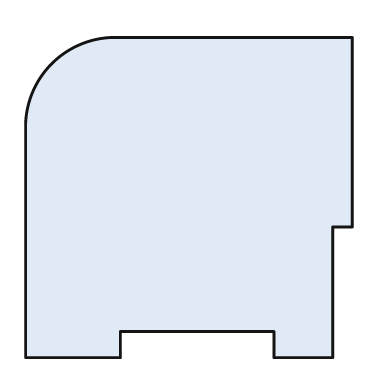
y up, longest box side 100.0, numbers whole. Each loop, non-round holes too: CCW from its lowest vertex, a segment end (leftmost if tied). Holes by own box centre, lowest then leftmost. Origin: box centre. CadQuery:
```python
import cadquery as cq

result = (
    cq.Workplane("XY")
    .moveTo(-50.0, -49.0)
    .lineTo(-21.0, -49.0)
    .lineTo(-21.0, -41.0)
    .lineTo(26.0, -41.0)
    .lineTo(26.0, -49.0)
    .lineTo(44.0, -49.0)
    .lineTo(44.0, -9.0)
    .lineTo(50.0, -9.0)
    .lineTo(50.0, 49.0)
    .lineTo(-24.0, 49.0)
    .threePointArc((-42.0, 41.0), (-50.0, 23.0))
    .close()
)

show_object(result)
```